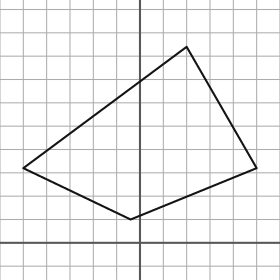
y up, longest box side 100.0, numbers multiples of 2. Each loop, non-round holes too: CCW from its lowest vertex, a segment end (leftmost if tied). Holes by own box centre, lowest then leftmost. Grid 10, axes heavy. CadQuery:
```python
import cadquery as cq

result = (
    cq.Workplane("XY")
    .moveTo(-4.0, 10.0)
    .lineTo(50.0, 32.0)
    .lineTo(20.0, 84.0)
    .lineTo(-50.0, 32.0)
    .close()
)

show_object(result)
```